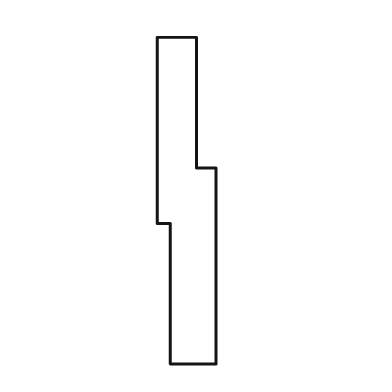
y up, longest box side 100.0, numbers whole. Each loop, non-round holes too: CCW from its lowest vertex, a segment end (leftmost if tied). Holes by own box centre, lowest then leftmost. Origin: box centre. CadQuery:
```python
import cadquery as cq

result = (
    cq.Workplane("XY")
    .moveTo(-5.0, -50.0)
    .lineTo(9.0, -50.0)
    .lineTo(9.0, 10.0)
    .lineTo(3.0, 10.0)
    .lineTo(3.0, 50.0)
    .lineTo(-9.0, 50.0)
    .lineTo(-9.0, -7.0)
    .lineTo(-5.0, -7.0)
    .close()
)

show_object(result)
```